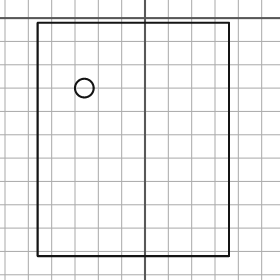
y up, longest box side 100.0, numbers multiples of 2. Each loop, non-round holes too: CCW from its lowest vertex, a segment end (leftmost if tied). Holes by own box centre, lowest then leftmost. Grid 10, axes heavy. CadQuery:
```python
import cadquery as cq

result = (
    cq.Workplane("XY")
    .moveTo(-46.0, -102.0)
    .lineTo(36.0, -102.0)
    .lineTo(36.0, -2.0)
    .lineTo(-46.0, -2.0)
    .close()
    .moveTo(-26.0, -30.0)
    .circle(4.0)
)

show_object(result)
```